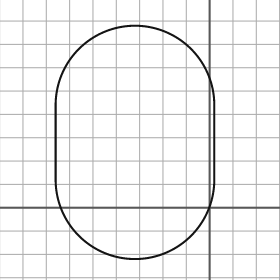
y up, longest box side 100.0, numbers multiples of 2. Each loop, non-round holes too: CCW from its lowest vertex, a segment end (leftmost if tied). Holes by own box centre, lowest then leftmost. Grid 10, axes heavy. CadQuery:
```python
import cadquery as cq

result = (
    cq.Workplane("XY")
    .moveTo(-66.0, 12.0)
    .threePointArc((-32.0, -22.0), (2.0, 12.0))
    .lineTo(2.0, 44.0)
    .threePointArc((-32.0, 78.0), (-66.0, 44.0))
    .close()
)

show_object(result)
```